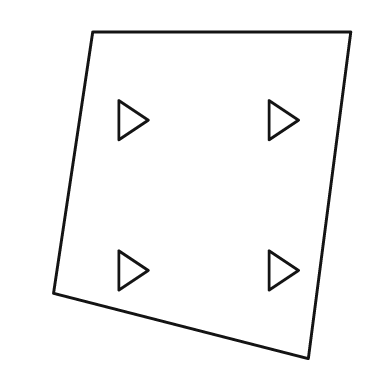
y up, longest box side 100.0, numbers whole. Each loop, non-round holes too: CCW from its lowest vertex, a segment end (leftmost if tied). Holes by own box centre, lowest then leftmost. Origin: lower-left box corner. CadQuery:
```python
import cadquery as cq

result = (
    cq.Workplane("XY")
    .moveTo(78.0, 0.0)
    .lineTo(91.0, 100.0)
    .lineTo(12.0, 100.0)
    .lineTo(0.0, 20.0)
    .close()
    .moveTo(20.0, 21.0)
    .lineTo(29.0, 27.0)
    .lineTo(20.0, 33.0)
    .close()
    .moveTo(66.0, 21.0)
    .lineTo(75.0, 27.0)
    .lineTo(66.0, 33.0)
    .close()
    .moveTo(20.0, 67.0)
    .lineTo(29.0, 73.0)
    .lineTo(20.0, 79.0)
    .close()
    .moveTo(66.0, 67.0)
    .lineTo(75.0, 73.0)
    .lineTo(66.0, 79.0)
    .close()
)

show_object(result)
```